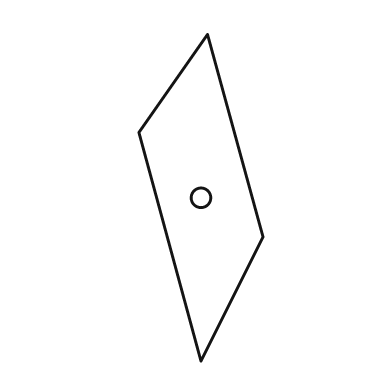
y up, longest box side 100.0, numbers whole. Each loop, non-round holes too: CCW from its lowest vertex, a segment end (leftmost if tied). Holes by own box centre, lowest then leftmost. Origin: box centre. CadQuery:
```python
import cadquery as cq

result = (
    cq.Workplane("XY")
    .moveTo(0.0, -50.0)
    .lineTo(19.0, -12.0)
    .lineTo(2.0, 50.0)
    .lineTo(-19.0, 20.0)
    .close()
    .moveTo(0.0, 0.0)
    .circle(3.0)
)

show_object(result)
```